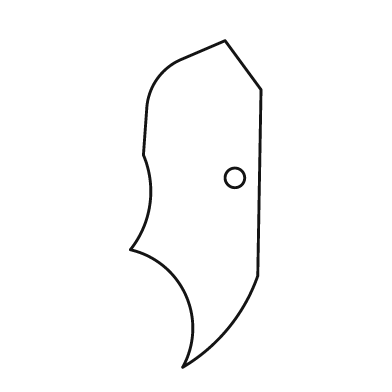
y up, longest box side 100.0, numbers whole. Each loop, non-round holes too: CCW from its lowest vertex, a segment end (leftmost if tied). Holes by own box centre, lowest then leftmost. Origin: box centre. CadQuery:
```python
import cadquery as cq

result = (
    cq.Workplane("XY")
    .moveTo(-4.0, -50.0)
    .threePointArc((10.0, -38.0), (19.0, -22.0))
    .lineTo(20.0, 35.0)
    .lineTo(9.0, 50.0)
    .lineTo(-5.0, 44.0)
    .threePointArc((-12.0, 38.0), (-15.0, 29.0))
    .lineTo(-16.0, 15.0)
    .threePointArc((-14.0, 0.0), (-20.0, -14.0))
    .threePointArc((-3.0, -28.0), (-4.0, -50.0))
    .close()
    .moveTo(12.0, 8.0)
    .circle(3.0)
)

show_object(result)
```